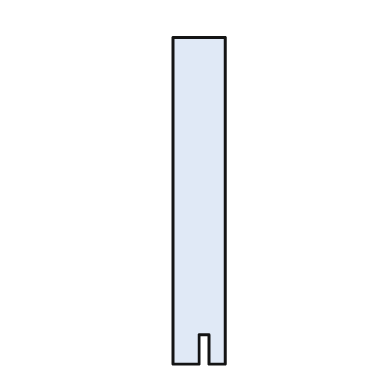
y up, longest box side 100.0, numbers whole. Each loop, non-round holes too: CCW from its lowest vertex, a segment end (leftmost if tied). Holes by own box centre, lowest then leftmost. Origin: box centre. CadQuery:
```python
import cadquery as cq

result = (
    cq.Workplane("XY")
    .moveTo(-8.0, -50.0)
    .lineTo(0.0, -50.0)
    .lineTo(0.0, -41.0)
    .lineTo(3.0, -41.0)
    .lineTo(3.0, -50.0)
    .lineTo(8.0, -50.0)
    .lineTo(8.0, 50.0)
    .lineTo(-8.0, 50.0)
    .close()
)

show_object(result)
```